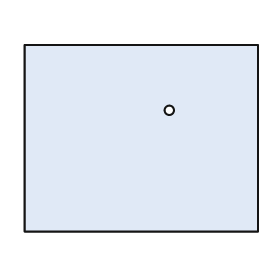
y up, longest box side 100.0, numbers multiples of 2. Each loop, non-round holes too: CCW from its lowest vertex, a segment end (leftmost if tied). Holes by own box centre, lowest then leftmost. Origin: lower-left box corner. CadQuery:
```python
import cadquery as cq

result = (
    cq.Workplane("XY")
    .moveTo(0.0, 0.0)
    .lineTo(100.0, 0.0)
    .lineTo(100.0, 80.0)
    .lineTo(0.0, 80.0)
    .close()
    .moveTo(62.0, 52.0)
    .circle(2.0)
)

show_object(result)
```